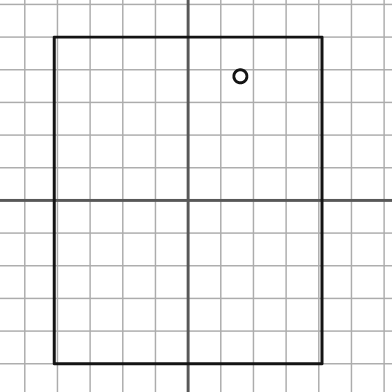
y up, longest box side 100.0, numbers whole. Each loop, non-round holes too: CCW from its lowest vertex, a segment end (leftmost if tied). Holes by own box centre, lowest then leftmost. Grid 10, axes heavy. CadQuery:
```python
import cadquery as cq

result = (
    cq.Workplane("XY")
    .moveTo(-41.0, -50.0)
    .lineTo(41.0, -50.0)
    .lineTo(41.0, 50.0)
    .lineTo(-41.0, 50.0)
    .close()
    .moveTo(16.0, 38.0)
    .circle(2.0)
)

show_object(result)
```